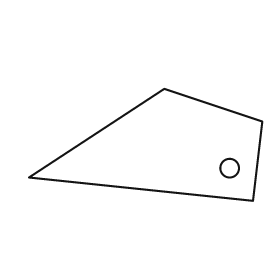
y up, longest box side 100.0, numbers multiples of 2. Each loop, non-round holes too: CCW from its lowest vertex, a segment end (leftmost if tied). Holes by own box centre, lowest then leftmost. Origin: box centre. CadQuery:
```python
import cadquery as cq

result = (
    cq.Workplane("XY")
    .moveTo(46.0, -24.0)
    .lineTo(50.0, 10.0)
    .lineTo(8.0, 24.0)
    .lineTo(-50.0, -14.0)
    .close()
    .moveTo(36.0, -10.0)
    .circle(4.0)
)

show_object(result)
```